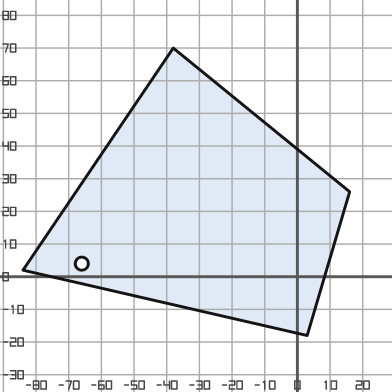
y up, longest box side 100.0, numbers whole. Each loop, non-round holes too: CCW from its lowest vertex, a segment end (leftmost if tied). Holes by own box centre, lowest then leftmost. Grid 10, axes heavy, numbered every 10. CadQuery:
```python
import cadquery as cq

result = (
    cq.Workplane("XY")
    .moveTo(3.0, -18.0)
    .lineTo(16.0, 26.0)
    .lineTo(-38.0, 70.0)
    .lineTo(-84.0, 2.0)
    .close()
    .moveTo(-66.0, 4.0)
    .circle(2.0)
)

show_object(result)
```